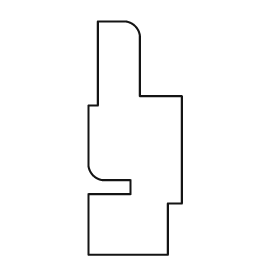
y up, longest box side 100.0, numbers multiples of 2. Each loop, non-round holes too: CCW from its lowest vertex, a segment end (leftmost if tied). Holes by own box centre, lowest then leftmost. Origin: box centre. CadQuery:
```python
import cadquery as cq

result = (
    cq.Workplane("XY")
    .moveTo(-20.0, -50.0)
    .lineTo(14.0, -50.0)
    .lineTo(14.0, -28.0)
    .lineTo(20.0, -28.0)
    .lineTo(20.0, 18.0)
    .lineTo(2.0, 18.0)
    .lineTo(2.0, 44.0)
    .threePointArc((0.0, 48.0), (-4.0, 50.0))
    .lineTo(-16.0, 50.0)
    .lineTo(-16.0, 14.0)
    .lineTo(-20.0, 14.0)
    .lineTo(-20.0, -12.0)
    .threePointArc((-18.0, -16.0), (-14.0, -18.0))
    .lineTo(-2.0, -18.0)
    .lineTo(-2.0, -24.0)
    .lineTo(-20.0, -24.0)
    .close()
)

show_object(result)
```